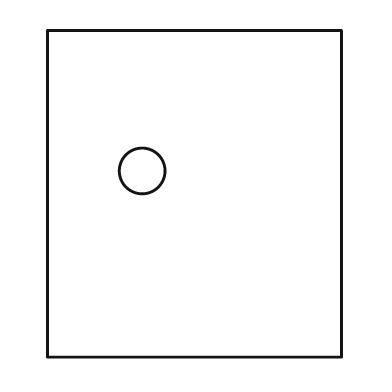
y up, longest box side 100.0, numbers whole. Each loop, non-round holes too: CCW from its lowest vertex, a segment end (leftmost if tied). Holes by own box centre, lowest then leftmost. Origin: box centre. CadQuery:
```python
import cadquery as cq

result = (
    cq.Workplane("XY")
    .moveTo(-45.0, -50.0)
    .lineTo(45.0, -50.0)
    .lineTo(45.0, 50.0)
    .lineTo(-45.0, 50.0)
    .close()
    .moveTo(-16.0, 7.0)
    .circle(7.0)
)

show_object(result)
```